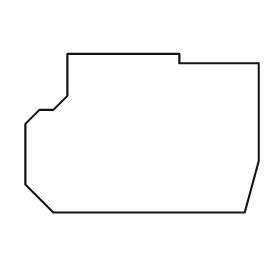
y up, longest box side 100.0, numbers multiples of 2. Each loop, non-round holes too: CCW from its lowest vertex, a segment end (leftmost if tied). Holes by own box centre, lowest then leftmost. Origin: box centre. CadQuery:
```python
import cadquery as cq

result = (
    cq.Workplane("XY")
    .moveTo(-38.0, -34.0)
    .lineTo(44.0, -34.0)
    .lineTo(50.0, -12.0)
    .lineTo(50.0, 30.0)
    .lineTo(16.0, 30.0)
    .lineTo(16.0, 34.0)
    .lineTo(-32.0, 34.0)
    .lineTo(-32.0, 16.0)
    .lineTo(-38.0, 10.0)
    .lineTo(-44.0, 10.0)
    .lineTo(-50.0, 4.0)
    .lineTo(-50.0, -22.0)
    .close()
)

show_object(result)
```